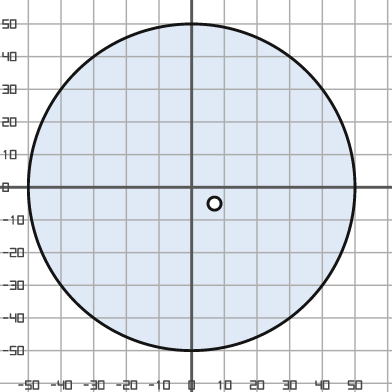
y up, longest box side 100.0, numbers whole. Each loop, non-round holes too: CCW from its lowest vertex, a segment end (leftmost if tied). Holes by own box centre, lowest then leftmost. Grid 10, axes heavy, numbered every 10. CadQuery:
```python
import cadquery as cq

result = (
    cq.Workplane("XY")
    .moveTo(0.0, 0.0)
    .circle(50.0)
    .moveTo(7.0, -5.0)
    .circle(2.0)
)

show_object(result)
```